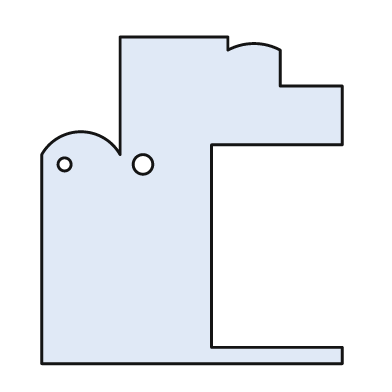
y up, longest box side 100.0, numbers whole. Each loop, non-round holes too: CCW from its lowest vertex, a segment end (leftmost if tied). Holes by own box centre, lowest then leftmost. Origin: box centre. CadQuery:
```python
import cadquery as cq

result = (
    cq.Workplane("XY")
    .moveTo(-46.0, -50.0)
    .lineTo(46.0, -50.0)
    .lineTo(46.0, -45.0)
    .lineTo(6.0, -45.0)
    .lineTo(6.0, 17.0)
    .lineTo(46.0, 17.0)
    .lineTo(46.0, 35.0)
    .lineTo(27.0, 35.0)
    .lineTo(27.0, 46.0)
    .threePointArc((19.0, 48.0), (11.0, 46.0))
    .lineTo(11.0, 50.0)
    .lineTo(-22.0, 50.0)
    .lineTo(-22.0, 14.0)
    .threePointArc((-34.0, 21.0), (-46.0, 14.0))
    .close()
    .moveTo(-39.0, 11.0)
    .circle(2.0)
    .moveTo(-15.0, 11.0)
    .circle(3.0)
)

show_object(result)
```